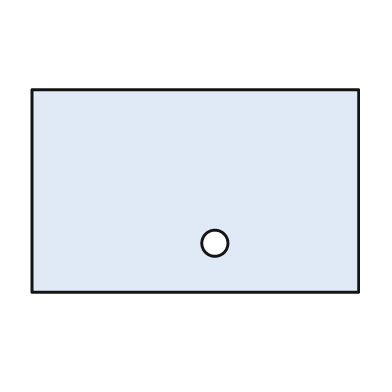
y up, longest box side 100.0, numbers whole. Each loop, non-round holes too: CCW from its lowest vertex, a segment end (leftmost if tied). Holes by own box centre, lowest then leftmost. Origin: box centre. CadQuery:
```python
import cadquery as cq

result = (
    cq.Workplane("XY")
    .moveTo(-50.0, -31.0)
    .lineTo(50.0, -31.0)
    .lineTo(50.0, 31.0)
    .lineTo(-50.0, 31.0)
    .close()
    .moveTo(6.0, -16.0)
    .circle(4.0)
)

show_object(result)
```